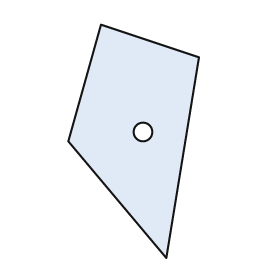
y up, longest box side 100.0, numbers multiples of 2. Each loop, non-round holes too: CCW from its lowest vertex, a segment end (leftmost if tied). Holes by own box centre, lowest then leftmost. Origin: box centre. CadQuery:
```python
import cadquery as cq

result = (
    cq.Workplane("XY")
    .moveTo(14.0, -50.0)
    .lineTo(28.0, 36.0)
    .lineTo(-14.0, 50.0)
    .lineTo(-28.0, 0.0)
    .close()
    .moveTo(4.0, 4.0)
    .circle(4.0)
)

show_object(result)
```